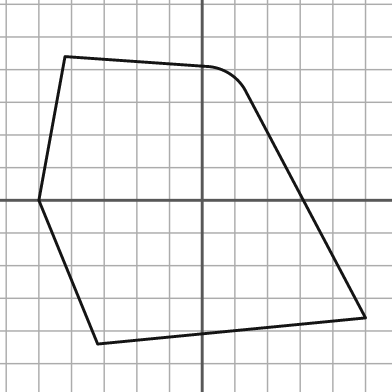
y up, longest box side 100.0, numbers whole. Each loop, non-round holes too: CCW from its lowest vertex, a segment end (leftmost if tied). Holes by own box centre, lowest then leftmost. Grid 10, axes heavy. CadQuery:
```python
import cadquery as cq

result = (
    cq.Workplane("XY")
    .moveTo(-32.0, -44.0)
    .lineTo(50.0, -36.0)
    .lineTo(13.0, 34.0)
    .threePointArc((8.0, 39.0), (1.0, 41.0))
    .lineTo(-42.0, 44.0)
    .lineTo(-50.0, 0.0)
    .close()
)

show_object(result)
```